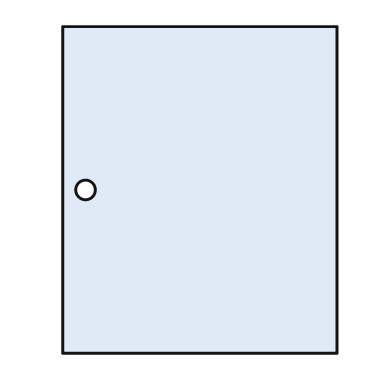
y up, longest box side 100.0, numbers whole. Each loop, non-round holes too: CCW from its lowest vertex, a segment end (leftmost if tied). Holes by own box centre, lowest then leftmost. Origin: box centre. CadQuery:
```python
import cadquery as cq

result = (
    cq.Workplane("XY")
    .moveTo(-42.0, -50.0)
    .lineTo(42.0, -50.0)
    .lineTo(42.0, 50.0)
    .lineTo(-42.0, 50.0)
    .close()
    .moveTo(-35.0, 0.0)
    .circle(3.0)
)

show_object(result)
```